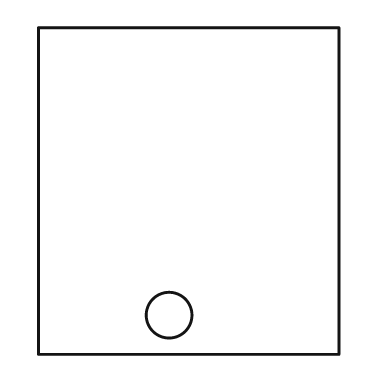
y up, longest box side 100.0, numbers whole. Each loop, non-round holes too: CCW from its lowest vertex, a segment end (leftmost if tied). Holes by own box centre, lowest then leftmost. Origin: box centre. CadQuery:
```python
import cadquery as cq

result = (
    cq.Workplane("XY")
    .moveTo(-46.0, -50.0)
    .lineTo(46.0, -50.0)
    .lineTo(46.0, 50.0)
    .lineTo(-46.0, 50.0)
    .close()
    .moveTo(-6.0, -38.0)
    .circle(7.0)
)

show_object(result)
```